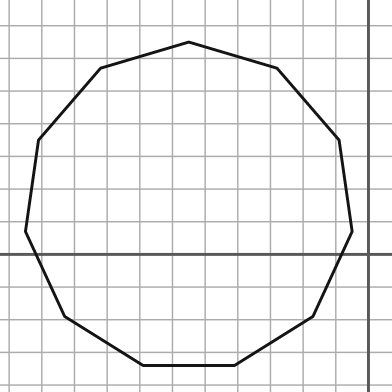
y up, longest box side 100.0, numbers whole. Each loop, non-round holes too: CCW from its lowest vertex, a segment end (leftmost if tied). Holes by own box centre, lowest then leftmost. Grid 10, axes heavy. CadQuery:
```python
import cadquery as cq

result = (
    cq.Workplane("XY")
    .moveTo(-69.0, -34.0)
    .lineTo(-41.0, -34.0)
    .lineTo(-17.0, -19.0)
    .lineTo(-5.0, 7.0)
    .lineTo(-9.0, 35.0)
    .lineTo(-28.0, 57.0)
    .lineTo(-55.0, 65.0)
    .lineTo(-82.0, 57.0)
    .lineTo(-101.0, 35.0)
    .lineTo(-105.0, 7.0)
    .lineTo(-93.0, -19.0)
    .close()
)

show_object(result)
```